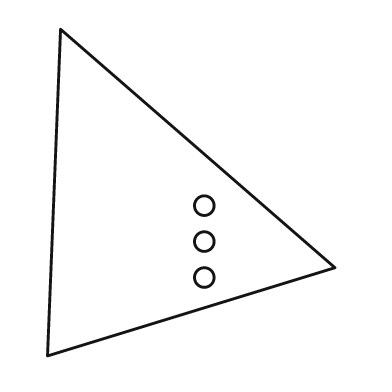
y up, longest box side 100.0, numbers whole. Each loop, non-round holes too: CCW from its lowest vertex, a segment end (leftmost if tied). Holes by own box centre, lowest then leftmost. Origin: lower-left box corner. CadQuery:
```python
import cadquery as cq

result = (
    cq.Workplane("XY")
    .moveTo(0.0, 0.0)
    .lineTo(88.0, 27.0)
    .lineTo(4.0, 100.0)
    .close()
    .moveTo(48.0, 24.0)
    .circle(3.0)
    .moveTo(48.0, 35.0)
    .circle(3.0)
    .moveTo(48.0, 46.0)
    .circle(3.0)
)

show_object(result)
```